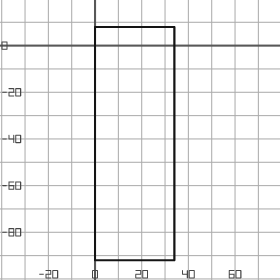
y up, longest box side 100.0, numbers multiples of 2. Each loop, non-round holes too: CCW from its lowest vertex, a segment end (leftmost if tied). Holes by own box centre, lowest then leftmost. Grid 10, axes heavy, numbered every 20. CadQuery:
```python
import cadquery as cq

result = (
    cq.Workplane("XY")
    .moveTo(0.0, -92.0)
    .lineTo(34.0, -92.0)
    .lineTo(34.0, 8.0)
    .lineTo(0.0, 8.0)
    .close()
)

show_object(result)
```